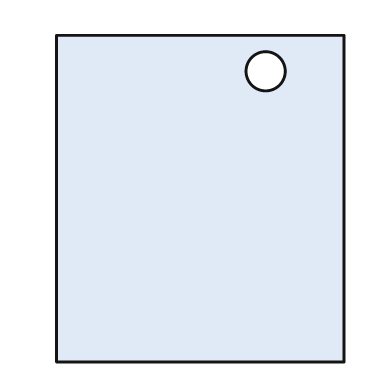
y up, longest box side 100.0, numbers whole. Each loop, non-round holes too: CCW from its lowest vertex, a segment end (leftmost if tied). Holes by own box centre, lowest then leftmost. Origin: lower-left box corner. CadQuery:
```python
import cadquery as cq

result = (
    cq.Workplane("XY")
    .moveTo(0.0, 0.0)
    .lineTo(88.0, 0.0)
    .lineTo(88.0, 100.0)
    .lineTo(0.0, 100.0)
    .close()
    .moveTo(64.0, 89.0)
    .circle(6.0)
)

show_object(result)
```